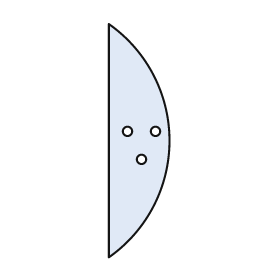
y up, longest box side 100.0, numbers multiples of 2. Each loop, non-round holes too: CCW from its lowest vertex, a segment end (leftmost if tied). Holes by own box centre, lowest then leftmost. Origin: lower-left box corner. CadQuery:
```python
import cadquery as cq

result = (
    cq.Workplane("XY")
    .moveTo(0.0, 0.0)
    .threePointArc((26.0, 50.0), (0.0, 100.0))
    .close()
    .moveTo(14.0, 42.0)
    .circle(2.0)
    .moveTo(8.0, 54.0)
    .circle(2.0)
    .moveTo(20.0, 54.0)
    .circle(2.0)
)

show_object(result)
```